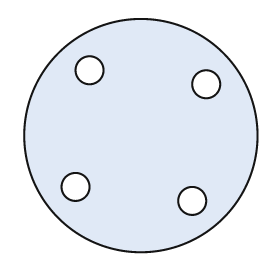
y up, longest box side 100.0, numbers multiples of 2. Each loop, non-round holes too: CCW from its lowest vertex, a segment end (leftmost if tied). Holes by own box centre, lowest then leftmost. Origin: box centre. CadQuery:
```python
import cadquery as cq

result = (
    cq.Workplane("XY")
    .moveTo(0.0, 0.0)
    .circle(50.0)
    .moveTo(22.0, -28.0)
    .circle(6.0)
    .moveTo(-28.0, -22.0)
    .circle(6.0)
    .moveTo(28.0, 22.0)
    .circle(6.0)
    .moveTo(-22.0, 28.0)
    .circle(6.0)
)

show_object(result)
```